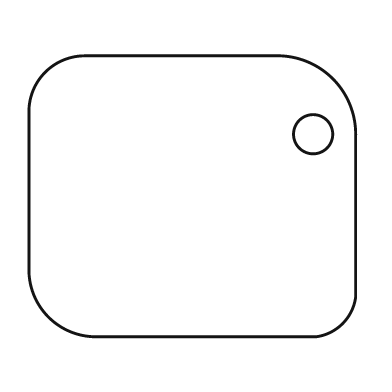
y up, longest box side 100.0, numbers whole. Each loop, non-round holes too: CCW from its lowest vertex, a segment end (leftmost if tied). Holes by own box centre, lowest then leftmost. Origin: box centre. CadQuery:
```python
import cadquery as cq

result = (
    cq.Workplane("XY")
    .moveTo(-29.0, -43.0)
    .lineTo(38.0, -43.0)
    .threePointArc((46.0, -39.0), (50.0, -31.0))
    .lineTo(50.0, 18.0)
    .threePointArc((43.0, 36.0), (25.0, 43.0))
    .lineTo(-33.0, 43.0)
    .threePointArc((-45.0, 38.0), (-50.0, 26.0))
    .lineTo(-50.0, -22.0)
    .threePointArc((-44.0, -37.0), (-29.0, -43.0))
    .close()
    .moveTo(37.0, 19.0)
    .circle(6.0)
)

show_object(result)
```